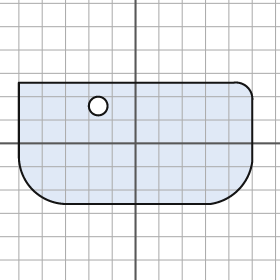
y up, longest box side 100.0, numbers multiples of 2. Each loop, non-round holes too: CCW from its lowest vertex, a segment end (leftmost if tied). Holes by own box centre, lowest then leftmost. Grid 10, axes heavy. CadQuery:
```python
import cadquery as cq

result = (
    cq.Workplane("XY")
    .moveTo(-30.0, -26.0)
    .lineTo(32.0, -26.0)
    .threePointArc((44.0, -20.0), (50.0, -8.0))
    .lineTo(50.0, 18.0)
    .threePointArc((48.0, 24.0), (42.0, 26.0))
    .lineTo(-50.0, 26.0)
    .lineTo(-50.0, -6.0)
    .threePointArc((-44.0, -20.0), (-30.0, -26.0))
    .close()
    .moveTo(-16.0, 16.0)
    .circle(4.0)
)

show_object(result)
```